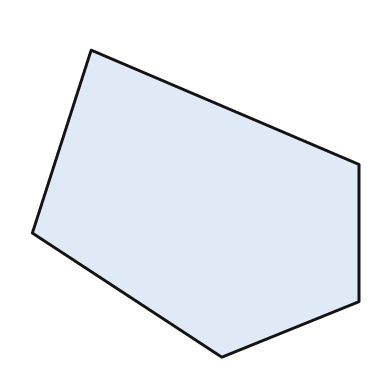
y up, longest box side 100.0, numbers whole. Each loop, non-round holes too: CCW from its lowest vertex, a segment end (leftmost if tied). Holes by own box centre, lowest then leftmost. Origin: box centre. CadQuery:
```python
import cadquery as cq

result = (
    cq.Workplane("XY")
    .moveTo(8.0, -47.0)
    .lineTo(50.0, -30.0)
    .lineTo(50.0, 12.0)
    .lineTo(-32.0, 47.0)
    .lineTo(-50.0, -9.0)
    .close()
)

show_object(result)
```